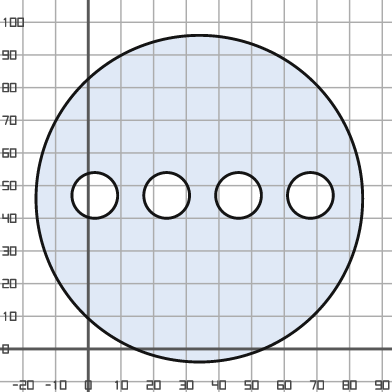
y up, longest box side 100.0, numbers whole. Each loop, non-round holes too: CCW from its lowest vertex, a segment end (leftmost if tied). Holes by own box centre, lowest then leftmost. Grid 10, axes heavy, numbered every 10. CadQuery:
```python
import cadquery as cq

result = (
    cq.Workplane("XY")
    .moveTo(34.0, 46.0)
    .circle(50.0)
    .moveTo(2.0, 47.0)
    .circle(7.0)
    .moveTo(24.0, 47.0)
    .circle(7.0)
    .moveTo(46.0, 47.0)
    .circle(7.0)
    .moveTo(68.0, 47.0)
    .circle(7.0)
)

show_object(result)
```